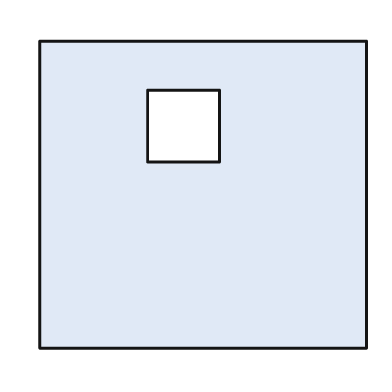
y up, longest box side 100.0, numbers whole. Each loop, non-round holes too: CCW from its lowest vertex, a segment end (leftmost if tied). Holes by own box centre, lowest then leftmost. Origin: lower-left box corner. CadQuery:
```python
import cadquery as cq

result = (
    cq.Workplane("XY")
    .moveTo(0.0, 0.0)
    .lineTo(100.0, 0.0)
    .lineTo(100.0, 94.0)
    .lineTo(0.0, 94.0)
    .close()
    .moveTo(33.0, 57.0)
    .lineTo(55.0, 57.0)
    .lineTo(55.0, 79.0)
    .lineTo(33.0, 79.0)
    .close()
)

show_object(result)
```